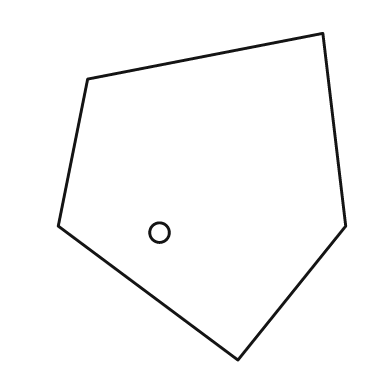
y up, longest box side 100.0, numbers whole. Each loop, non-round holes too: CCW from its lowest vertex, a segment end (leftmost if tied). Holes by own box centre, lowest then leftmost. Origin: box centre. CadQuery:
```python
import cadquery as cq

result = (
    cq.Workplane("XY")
    .moveTo(11.0, -50.0)
    .lineTo(44.0, -9.0)
    .lineTo(37.0, 50.0)
    .lineTo(-35.0, 36.0)
    .lineTo(-44.0, -9.0)
    .close()
    .moveTo(-13.0, -11.0)
    .circle(3.0)
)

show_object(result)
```